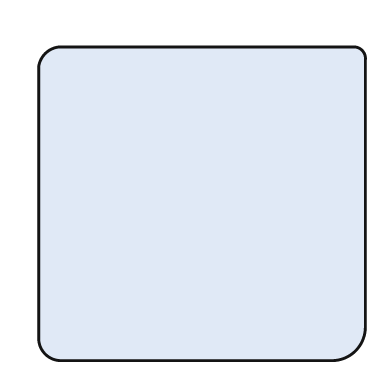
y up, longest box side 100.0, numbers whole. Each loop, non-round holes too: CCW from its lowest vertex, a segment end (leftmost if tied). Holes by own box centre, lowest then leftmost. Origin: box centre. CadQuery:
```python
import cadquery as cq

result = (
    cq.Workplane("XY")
    .moveTo(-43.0, -48.0)
    .lineTo(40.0, -48.0)
    .threePointArc((47.0, -45.0), (50.0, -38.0))
    .lineTo(50.0, 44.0)
    .threePointArc((49.0, 47.0), (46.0, 48.0))
    .lineTo(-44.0, 48.0)
    .threePointArc((-48.0, 46.0), (-50.0, 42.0))
    .lineTo(-50.0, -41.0)
    .threePointArc((-48.0, -46.0), (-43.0, -48.0))
    .close()
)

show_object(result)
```